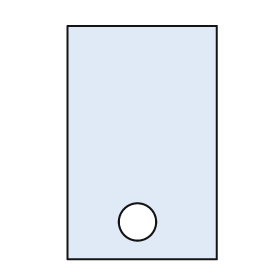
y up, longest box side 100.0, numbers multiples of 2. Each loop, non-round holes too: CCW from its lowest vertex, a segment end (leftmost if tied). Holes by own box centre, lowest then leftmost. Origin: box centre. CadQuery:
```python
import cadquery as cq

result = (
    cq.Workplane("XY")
    .moveTo(-32.0, -50.0)
    .lineTo(32.0, -50.0)
    .lineTo(32.0, 50.0)
    .lineTo(-32.0, 50.0)
    .close()
    .moveTo(-2.0, -34.0)
    .circle(8.0)
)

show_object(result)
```